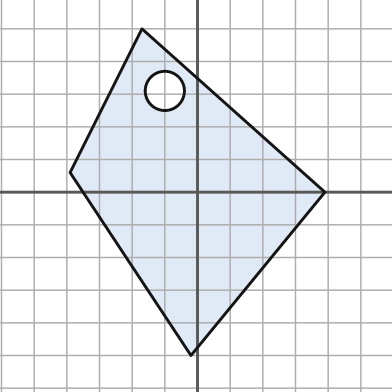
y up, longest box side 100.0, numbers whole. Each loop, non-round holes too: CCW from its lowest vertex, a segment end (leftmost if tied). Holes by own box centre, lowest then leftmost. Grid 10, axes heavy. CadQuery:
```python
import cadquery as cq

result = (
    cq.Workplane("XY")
    .moveTo(-2.0, -50.0)
    .lineTo(39.0, 0.0)
    .lineTo(-17.0, 50.0)
    .lineTo(-39.0, 6.0)
    .close()
    .moveTo(-10.0, 31.0)
    .circle(6.0)
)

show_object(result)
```